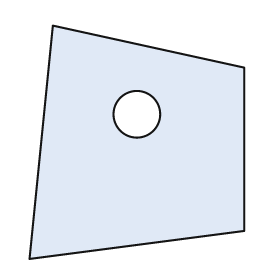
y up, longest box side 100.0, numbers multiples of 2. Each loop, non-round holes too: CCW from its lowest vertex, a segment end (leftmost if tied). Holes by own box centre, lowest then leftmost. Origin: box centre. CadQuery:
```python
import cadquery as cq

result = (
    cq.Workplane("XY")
    .moveTo(-46.0, -50.0)
    .lineTo(46.0, -38.0)
    .lineTo(46.0, 32.0)
    .lineTo(-36.0, 50.0)
    .close()
    .moveTo(0.0, 12.0)
    .circle(10.0)
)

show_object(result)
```